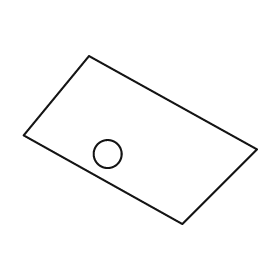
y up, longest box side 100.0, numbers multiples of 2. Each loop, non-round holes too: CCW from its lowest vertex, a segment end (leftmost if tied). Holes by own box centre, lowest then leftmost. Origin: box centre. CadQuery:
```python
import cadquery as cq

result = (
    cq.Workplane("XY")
    .moveTo(18.0, -36.0)
    .lineTo(50.0, -4.0)
    .lineTo(-22.0, 36.0)
    .lineTo(-50.0, 2.0)
    .close()
    .moveTo(-14.0, -6.0)
    .circle(6.0)
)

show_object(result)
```